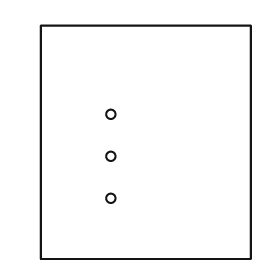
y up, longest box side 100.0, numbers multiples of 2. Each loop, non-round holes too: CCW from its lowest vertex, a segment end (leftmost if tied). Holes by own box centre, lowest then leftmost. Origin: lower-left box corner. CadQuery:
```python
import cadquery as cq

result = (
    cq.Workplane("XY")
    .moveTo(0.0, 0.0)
    .lineTo(90.0, 0.0)
    .lineTo(90.0, 100.0)
    .lineTo(0.0, 100.0)
    .close()
    .moveTo(30.0, 26.0)
    .circle(2.0)
    .moveTo(30.0, 44.0)
    .circle(2.0)
    .moveTo(30.0, 62.0)
    .circle(2.0)
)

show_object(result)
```